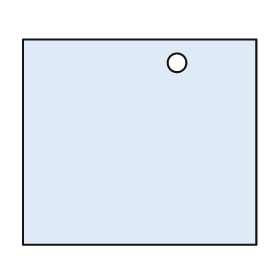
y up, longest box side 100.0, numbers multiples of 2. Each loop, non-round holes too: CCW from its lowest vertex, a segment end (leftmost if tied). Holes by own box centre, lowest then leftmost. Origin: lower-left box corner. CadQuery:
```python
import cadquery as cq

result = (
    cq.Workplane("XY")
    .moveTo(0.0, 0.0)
    .lineTo(100.0, 0.0)
    .lineTo(100.0, 88.0)
    .lineTo(0.0, 88.0)
    .close()
    .moveTo(66.0, 78.0)
    .circle(4.0)
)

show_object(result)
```